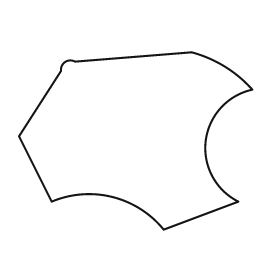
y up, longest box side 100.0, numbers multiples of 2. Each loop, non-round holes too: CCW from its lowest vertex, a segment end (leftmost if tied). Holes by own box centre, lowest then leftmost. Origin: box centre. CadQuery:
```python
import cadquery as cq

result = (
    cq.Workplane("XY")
    .moveTo(12.0, -38.0)
    .lineTo(44.0, -26.0)
    .threePointArc((30.0, 0.0), (50.0, 22.0))
    .threePointArc((38.0, 32.0), (24.0, 38.0))
    .lineTo(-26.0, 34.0)
    .threePointArc((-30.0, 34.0), (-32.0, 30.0))
    .lineTo(-50.0, 2.0)
    .lineTo(-36.0, -26.0)
    .threePointArc((-10.0, -24.0), (12.0, -38.0))
    .close()
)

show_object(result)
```